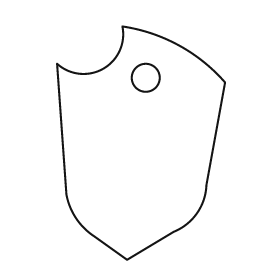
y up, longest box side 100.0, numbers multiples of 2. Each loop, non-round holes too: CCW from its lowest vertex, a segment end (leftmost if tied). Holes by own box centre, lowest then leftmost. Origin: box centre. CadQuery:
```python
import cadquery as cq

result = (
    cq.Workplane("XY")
    .moveTo(-6.0, -50.0)
    .lineTo(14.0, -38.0)
    .threePointArc((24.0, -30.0), (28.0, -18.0))
    .lineTo(36.0, 26.0)
    .threePointArc((16.0, 42.0), (-8.0, 50.0))
    .threePointArc((-16.0, 32.0), (-36.0, 34.0))
    .lineTo(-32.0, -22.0)
    .threePointArc((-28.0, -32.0), (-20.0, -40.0))
    .close()
    .moveTo(2.0, 28.0)
    .circle(6.0)
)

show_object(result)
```